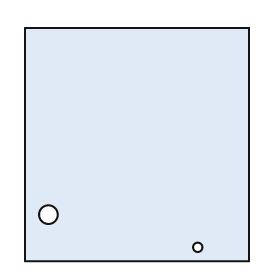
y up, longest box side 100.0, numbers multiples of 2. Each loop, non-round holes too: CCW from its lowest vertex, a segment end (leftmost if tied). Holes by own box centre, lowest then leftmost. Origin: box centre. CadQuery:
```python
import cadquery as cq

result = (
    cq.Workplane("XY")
    .moveTo(-48.0, -50.0)
    .lineTo(48.0, -50.0)
    .lineTo(48.0, 50.0)
    .lineTo(-48.0, 50.0)
    .close()
    .moveTo(26.0, -44.0)
    .circle(2.0)
    .moveTo(-38.0, -30.0)
    .circle(4.0)
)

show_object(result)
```